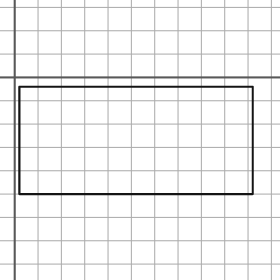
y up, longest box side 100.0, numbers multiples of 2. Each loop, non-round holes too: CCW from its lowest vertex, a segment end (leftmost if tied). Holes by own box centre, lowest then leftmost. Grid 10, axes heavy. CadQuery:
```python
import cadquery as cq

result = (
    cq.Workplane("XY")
    .moveTo(2.0, -50.0)
    .lineTo(102.0, -50.0)
    .lineTo(102.0, -4.0)
    .lineTo(2.0, -4.0)
    .close()
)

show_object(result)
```